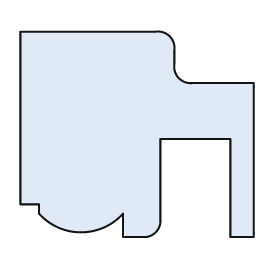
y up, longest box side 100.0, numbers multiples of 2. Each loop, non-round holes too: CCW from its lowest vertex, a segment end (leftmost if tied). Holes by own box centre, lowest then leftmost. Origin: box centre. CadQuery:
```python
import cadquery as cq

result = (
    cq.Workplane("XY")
    .moveTo(-6.0, -44.0)
    .lineTo(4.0, -44.0)
    .threePointArc((8.0, -42.0), (10.0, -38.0))
    .lineTo(10.0, -2.0)
    .lineTo(40.0, -2.0)
    .lineTo(40.0, -44.0)
    .lineTo(50.0, -44.0)
    .lineTo(50.0, 22.0)
    .lineTo(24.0, 22.0)
    .threePointArc((18.0, 24.0), (16.0, 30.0))
    .lineTo(16.0, 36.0)
    .threePointArc((14.0, 42.0), (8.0, 44.0))
    .lineTo(-50.0, 44.0)
    .lineTo(-50.0, -30.0)
    .lineTo(-42.0, -30.0)
    .lineTo(-42.0, -34.0)
    .threePointArc((-24.0, -42.0), (-6.0, -34.0))
    .close()
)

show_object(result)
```